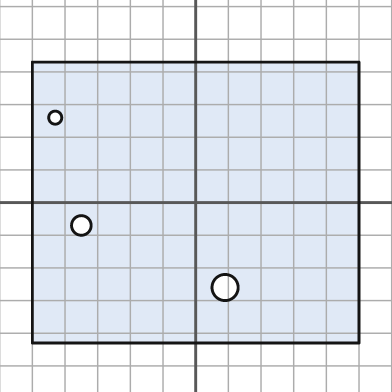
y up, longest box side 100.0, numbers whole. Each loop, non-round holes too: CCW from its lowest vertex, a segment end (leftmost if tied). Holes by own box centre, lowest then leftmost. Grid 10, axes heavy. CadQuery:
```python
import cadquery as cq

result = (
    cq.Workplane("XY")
    .moveTo(-50.0, -43.0)
    .lineTo(50.0, -43.0)
    .lineTo(50.0, 43.0)
    .lineTo(-50.0, 43.0)
    .close()
    .moveTo(9.0, -26.0)
    .circle(4.0)
    .moveTo(-35.0, -7.0)
    .circle(3.0)
    .moveTo(-43.0, 26.0)
    .circle(2.0)
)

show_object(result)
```